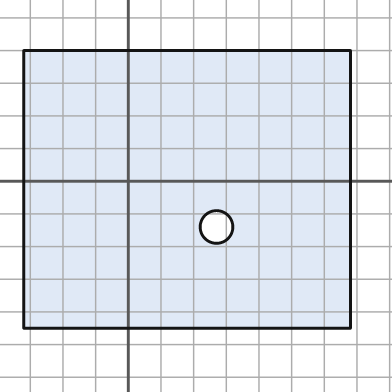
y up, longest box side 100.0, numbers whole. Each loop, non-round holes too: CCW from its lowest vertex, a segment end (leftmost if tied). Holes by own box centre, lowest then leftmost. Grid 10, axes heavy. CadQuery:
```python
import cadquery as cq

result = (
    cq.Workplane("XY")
    .moveTo(-32.0, -45.0)
    .lineTo(68.0, -45.0)
    .lineTo(68.0, 40.0)
    .lineTo(-32.0, 40.0)
    .close()
    .moveTo(27.0, -14.0)
    .circle(5.0)
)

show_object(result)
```